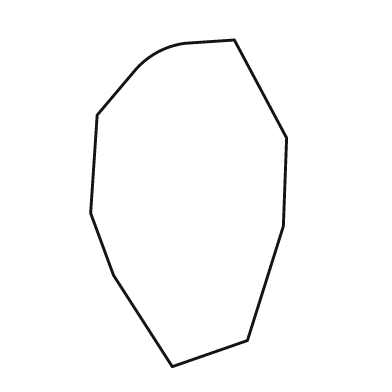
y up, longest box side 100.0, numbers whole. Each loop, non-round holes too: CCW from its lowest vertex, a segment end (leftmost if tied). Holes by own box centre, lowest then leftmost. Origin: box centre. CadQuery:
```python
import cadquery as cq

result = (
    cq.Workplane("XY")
    .moveTo(-5.0, -50.0)
    .lineTo(18.0, -42.0)
    .lineTo(29.0, -7.0)
    .lineTo(30.0, 20.0)
    .lineTo(14.0, 50.0)
    .lineTo(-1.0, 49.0)
    .threePointArc((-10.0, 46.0), (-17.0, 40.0))
    .lineTo(-28.0, 27.0)
    .lineTo(-30.0, -3.0)
    .lineTo(-23.0, -22.0)
    .close()
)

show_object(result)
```